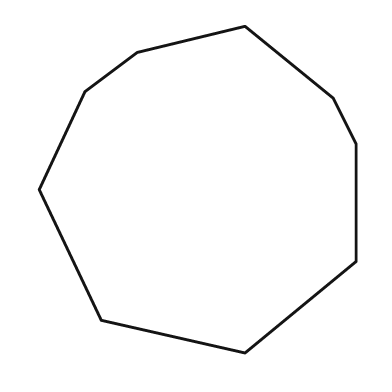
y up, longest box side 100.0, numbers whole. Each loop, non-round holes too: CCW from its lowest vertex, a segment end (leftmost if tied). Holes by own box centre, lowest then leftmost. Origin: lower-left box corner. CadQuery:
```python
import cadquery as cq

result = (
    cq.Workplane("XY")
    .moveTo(63.0, 0.0)
    .lineTo(97.0, 28.0)
    .lineTo(97.0, 64.0)
    .lineTo(90.0, 78.0)
    .lineTo(63.0, 100.0)
    .lineTo(30.0, 92.0)
    .lineTo(14.0, 80.0)
    .lineTo(0.0, 50.0)
    .lineTo(19.0, 10.0)
    .close()
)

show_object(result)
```